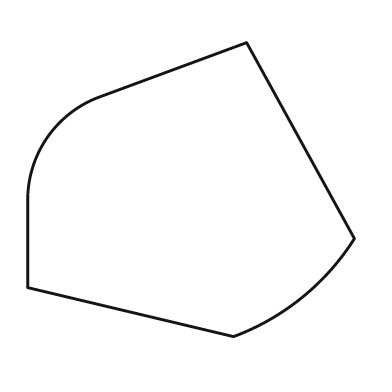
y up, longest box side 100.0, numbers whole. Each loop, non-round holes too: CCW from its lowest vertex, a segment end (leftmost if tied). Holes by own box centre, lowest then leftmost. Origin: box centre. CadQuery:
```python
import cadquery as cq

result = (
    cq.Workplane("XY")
    .moveTo(13.0, -45.0)
    .threePointArc((34.0, -33.0), (50.0, -15.0))
    .lineTo(17.0, 45.0)
    .lineTo(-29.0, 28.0)
    .threePointArc((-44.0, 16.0), (-50.0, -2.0))
    .lineTo(-50.0, -30.0)
    .close()
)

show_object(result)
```